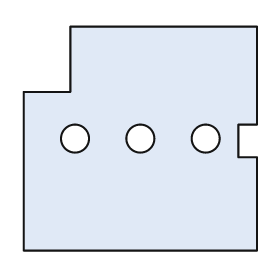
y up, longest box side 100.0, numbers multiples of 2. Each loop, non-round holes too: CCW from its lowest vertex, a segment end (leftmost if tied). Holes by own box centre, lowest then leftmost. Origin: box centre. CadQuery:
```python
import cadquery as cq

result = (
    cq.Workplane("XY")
    .moveTo(-50.0, -48.0)
    .lineTo(50.0, -48.0)
    .lineTo(50.0, -8.0)
    .lineTo(42.0, -8.0)
    .lineTo(42.0, 6.0)
    .lineTo(50.0, 6.0)
    .lineTo(50.0, 48.0)
    .lineTo(-30.0, 48.0)
    .lineTo(-30.0, 20.0)
    .lineTo(-50.0, 20.0)
    .close()
    .moveTo(-28.0, 0.0)
    .circle(6.0)
    .moveTo(0.0, 0.0)
    .circle(6.0)
    .moveTo(28.0, 0.0)
    .circle(6.0)
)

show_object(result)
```